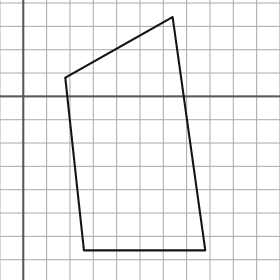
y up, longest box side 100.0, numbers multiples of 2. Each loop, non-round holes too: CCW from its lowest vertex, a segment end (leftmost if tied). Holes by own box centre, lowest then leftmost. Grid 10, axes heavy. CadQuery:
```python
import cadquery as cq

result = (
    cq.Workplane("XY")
    .moveTo(26.0, -66.0)
    .lineTo(78.0, -66.0)
    .lineTo(64.0, 34.0)
    .lineTo(18.0, 8.0)
    .close()
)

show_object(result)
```